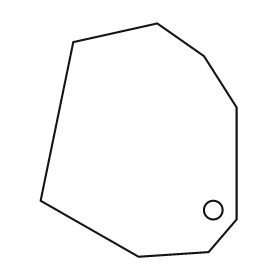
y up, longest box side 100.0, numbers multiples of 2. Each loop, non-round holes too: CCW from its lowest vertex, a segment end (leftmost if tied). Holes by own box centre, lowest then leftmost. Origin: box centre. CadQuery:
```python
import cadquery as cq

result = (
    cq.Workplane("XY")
    .moveTo(0.0, -50.0)
    .lineTo(30.0, -48.0)
    .lineTo(42.0, -34.0)
    .lineTo(42.0, 14.0)
    .lineTo(28.0, 36.0)
    .lineTo(8.0, 50.0)
    .lineTo(-28.0, 42.0)
    .lineTo(-42.0, -26.0)
    .close()
    .moveTo(32.0, -30.0)
    .circle(4.0)
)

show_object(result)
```